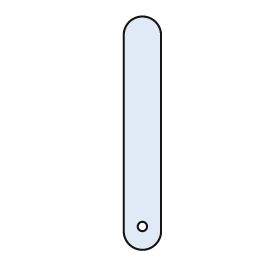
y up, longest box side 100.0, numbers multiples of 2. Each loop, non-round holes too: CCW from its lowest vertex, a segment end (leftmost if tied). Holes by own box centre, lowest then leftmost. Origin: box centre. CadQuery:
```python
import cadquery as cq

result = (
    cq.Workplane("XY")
    .moveTo(-8.0, -42.0)
    .threePointArc((0.0, -50.0), (8.0, -42.0))
    .lineTo(8.0, 42.0)
    .threePointArc((0.0, 50.0), (-8.0, 42.0))
    .close()
    .moveTo(0.0, -40.0)
    .circle(2.0)
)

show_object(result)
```